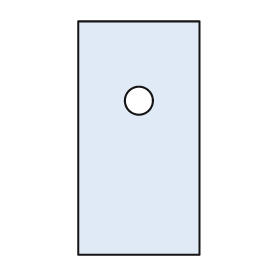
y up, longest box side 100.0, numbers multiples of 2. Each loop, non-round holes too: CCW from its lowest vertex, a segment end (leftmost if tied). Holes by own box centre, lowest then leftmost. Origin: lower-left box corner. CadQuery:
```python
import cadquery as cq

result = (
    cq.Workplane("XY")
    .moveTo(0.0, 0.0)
    .lineTo(52.0, 0.0)
    .lineTo(52.0, 100.0)
    .lineTo(0.0, 100.0)
    .close()
    .moveTo(26.0, 66.0)
    .circle(6.0)
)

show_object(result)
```